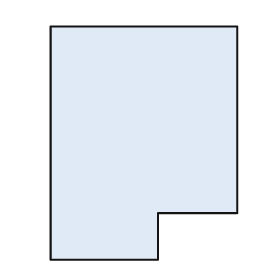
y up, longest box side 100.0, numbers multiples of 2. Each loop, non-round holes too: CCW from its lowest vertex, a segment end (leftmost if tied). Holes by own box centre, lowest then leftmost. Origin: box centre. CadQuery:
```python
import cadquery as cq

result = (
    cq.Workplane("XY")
    .moveTo(-40.0, -50.0)
    .lineTo(6.0, -50.0)
    .lineTo(6.0, -30.0)
    .lineTo(40.0, -30.0)
    .lineTo(40.0, 50.0)
    .lineTo(-40.0, 50.0)
    .close()
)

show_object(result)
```